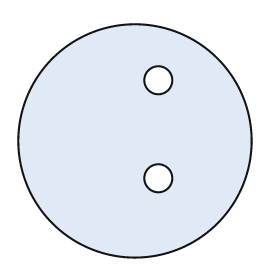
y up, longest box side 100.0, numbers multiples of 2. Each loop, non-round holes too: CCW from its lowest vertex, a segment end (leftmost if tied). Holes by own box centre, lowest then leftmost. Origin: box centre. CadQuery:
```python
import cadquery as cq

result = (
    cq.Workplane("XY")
    .moveTo(0.0, 0.0)
    .circle(50.0)
    .moveTo(10.0, -16.0)
    .circle(6.0)
    .moveTo(10.0, 26.0)
    .circle(6.0)
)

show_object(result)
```